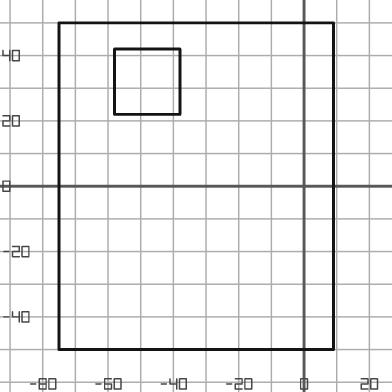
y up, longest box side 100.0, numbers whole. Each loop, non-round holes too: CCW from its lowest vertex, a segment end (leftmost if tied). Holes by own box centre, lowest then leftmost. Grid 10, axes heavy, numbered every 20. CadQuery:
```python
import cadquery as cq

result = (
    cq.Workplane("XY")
    .moveTo(-75.0, -50.0)
    .lineTo(9.0, -50.0)
    .lineTo(9.0, 50.0)
    .lineTo(-75.0, 50.0)
    .close()
    .moveTo(-58.0, 22.0)
    .lineTo(-38.0, 22.0)
    .lineTo(-38.0, 42.0)
    .lineTo(-58.0, 42.0)
    .close()
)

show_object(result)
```